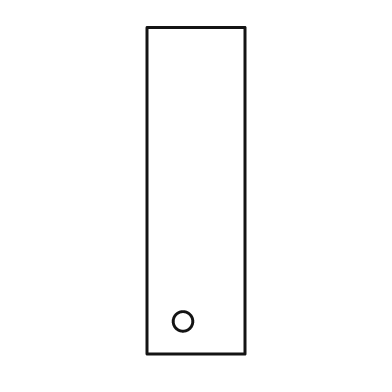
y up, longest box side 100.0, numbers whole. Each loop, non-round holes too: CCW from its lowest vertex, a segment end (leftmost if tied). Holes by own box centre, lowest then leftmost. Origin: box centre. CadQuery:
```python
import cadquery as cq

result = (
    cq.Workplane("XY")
    .moveTo(-15.0, -50.0)
    .lineTo(15.0, -50.0)
    .lineTo(15.0, 50.0)
    .lineTo(-15.0, 50.0)
    .close()
    .moveTo(-4.0, -40.0)
    .circle(3.0)
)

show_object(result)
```